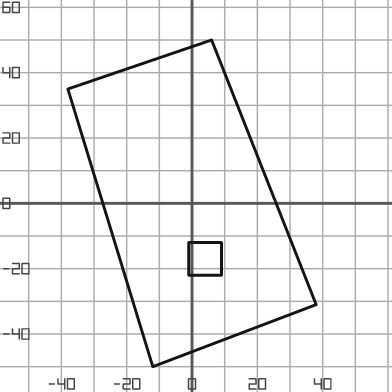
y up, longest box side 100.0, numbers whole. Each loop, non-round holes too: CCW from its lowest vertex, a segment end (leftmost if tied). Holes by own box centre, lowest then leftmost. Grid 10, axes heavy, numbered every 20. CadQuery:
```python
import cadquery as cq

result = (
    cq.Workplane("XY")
    .moveTo(-12.0, -50.0)
    .lineTo(38.0, -31.0)
    .lineTo(6.0, 50.0)
    .lineTo(-38.0, 35.0)
    .close()
    .moveTo(-1.0, -22.0)
    .lineTo(9.0, -22.0)
    .lineTo(9.0, -12.0)
    .lineTo(-1.0, -12.0)
    .close()
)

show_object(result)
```